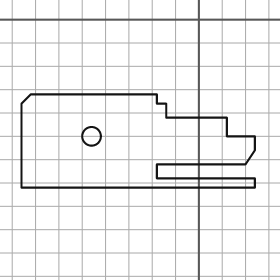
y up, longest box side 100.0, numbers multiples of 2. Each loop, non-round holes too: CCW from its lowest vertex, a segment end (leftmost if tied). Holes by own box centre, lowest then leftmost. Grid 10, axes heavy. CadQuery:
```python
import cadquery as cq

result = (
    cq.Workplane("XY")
    .moveTo(-76.0, -72.0)
    .lineTo(24.0, -72.0)
    .lineTo(24.0, -68.0)
    .lineTo(-18.0, -68.0)
    .lineTo(-18.0, -62.0)
    .lineTo(20.0, -62.0)
    .lineTo(24.0, -56.0)
    .lineTo(24.0, -50.0)
    .lineTo(12.0, -50.0)
    .lineTo(12.0, -42.0)
    .lineTo(-14.0, -42.0)
    .lineTo(-14.0, -36.0)
    .lineTo(-18.0, -36.0)
    .lineTo(-18.0, -32.0)
    .lineTo(-72.0, -32.0)
    .lineTo(-76.0, -36.0)
    .close()
    .moveTo(-46.0, -50.0)
    .circle(4.0)
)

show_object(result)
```